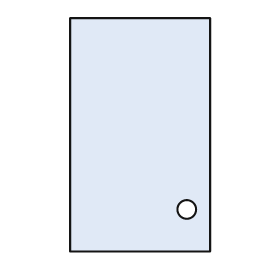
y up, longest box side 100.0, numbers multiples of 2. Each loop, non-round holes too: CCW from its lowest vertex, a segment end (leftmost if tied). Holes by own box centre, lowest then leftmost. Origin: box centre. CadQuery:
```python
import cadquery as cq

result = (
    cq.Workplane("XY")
    .moveTo(-30.0, -50.0)
    .lineTo(30.0, -50.0)
    .lineTo(30.0, 50.0)
    .lineTo(-30.0, 50.0)
    .close()
    .moveTo(20.0, -32.0)
    .circle(4.0)
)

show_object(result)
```